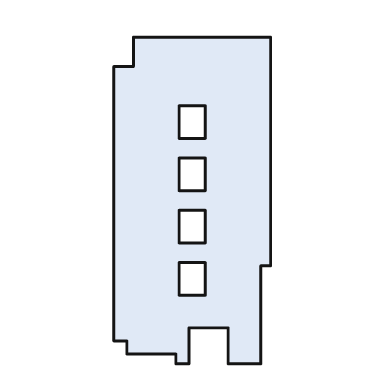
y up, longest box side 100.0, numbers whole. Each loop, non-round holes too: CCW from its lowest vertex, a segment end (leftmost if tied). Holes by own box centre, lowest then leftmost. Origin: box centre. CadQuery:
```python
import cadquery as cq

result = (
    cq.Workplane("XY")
    .moveTo(-5.0, -50.0)
    .lineTo(-1.0, -50.0)
    .lineTo(-1.0, -39.0)
    .lineTo(11.0, -39.0)
    .lineTo(11.0, -50.0)
    .lineTo(21.0, -50.0)
    .lineTo(21.0, -20.0)
    .lineTo(24.0, -20.0)
    .lineTo(24.0, 50.0)
    .lineTo(-18.0, 50.0)
    .lineTo(-18.0, 41.0)
    .lineTo(-24.0, 41.0)
    .lineTo(-24.0, -43.0)
    .lineTo(-20.0, -43.0)
    .lineTo(-20.0, -47.0)
    .lineTo(-5.0, -47.0)
    .close()
    .moveTo(-4.0, -29.0)
    .lineTo(4.0, -29.0)
    .lineTo(4.0, -19.0)
    .lineTo(-4.0, -19.0)
    .close()
    .moveTo(-4.0, -13.0)
    .lineTo(4.0, -13.0)
    .lineTo(4.0, -3.0)
    .lineTo(-4.0, -3.0)
    .close()
    .moveTo(-4.0, 3.0)
    .lineTo(4.0, 3.0)
    .lineTo(4.0, 13.0)
    .lineTo(-4.0, 13.0)
    .close()
    .moveTo(-4.0, 19.0)
    .lineTo(4.0, 19.0)
    .lineTo(4.0, 29.0)
    .lineTo(-4.0, 29.0)
    .close()
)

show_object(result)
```